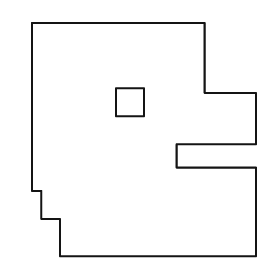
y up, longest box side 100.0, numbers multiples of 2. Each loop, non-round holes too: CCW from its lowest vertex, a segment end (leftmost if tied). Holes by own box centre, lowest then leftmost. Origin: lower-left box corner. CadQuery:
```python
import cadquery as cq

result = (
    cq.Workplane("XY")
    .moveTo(12.0, 0.0)
    .lineTo(96.0, 0.0)
    .lineTo(96.0, 38.0)
    .lineTo(62.0, 38.0)
    .lineTo(62.0, 48.0)
    .lineTo(96.0, 48.0)
    .lineTo(96.0, 70.0)
    .lineTo(74.0, 70.0)
    .lineTo(74.0, 100.0)
    .lineTo(0.0, 100.0)
    .lineTo(0.0, 28.0)
    .lineTo(4.0, 28.0)
    .lineTo(4.0, 16.0)
    .lineTo(12.0, 16.0)
    .close()
    .moveTo(36.0, 60.0)
    .lineTo(48.0, 60.0)
    .lineTo(48.0, 72.0)
    .lineTo(36.0, 72.0)
    .close()
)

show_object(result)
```